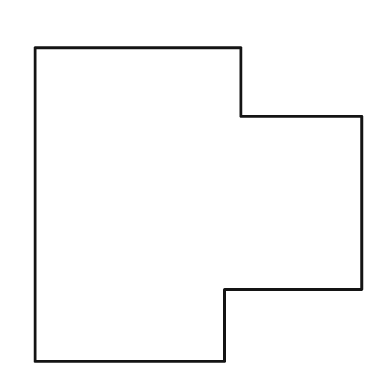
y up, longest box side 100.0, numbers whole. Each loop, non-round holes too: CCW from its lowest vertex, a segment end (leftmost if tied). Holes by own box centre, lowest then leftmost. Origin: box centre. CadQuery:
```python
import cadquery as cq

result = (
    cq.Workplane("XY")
    .moveTo(-50.0, -48.0)
    .lineTo(8.0, -48.0)
    .lineTo(8.0, -26.0)
    .lineTo(50.0, -26.0)
    .lineTo(50.0, 27.0)
    .lineTo(13.0, 27.0)
    .lineTo(13.0, 48.0)
    .lineTo(-50.0, 48.0)
    .close()
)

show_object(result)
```